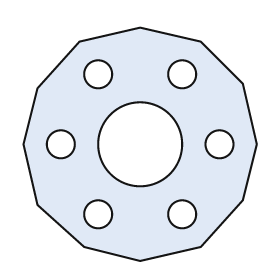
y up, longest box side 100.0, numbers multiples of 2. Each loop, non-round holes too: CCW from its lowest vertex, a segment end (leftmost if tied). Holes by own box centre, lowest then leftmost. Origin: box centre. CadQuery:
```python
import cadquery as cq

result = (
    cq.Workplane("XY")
    .moveTo(0.0, -50.0)
    .lineTo(26.0, -44.0)
    .lineTo(44.0, -24.0)
    .lineTo(50.0, 0.0)
    .lineTo(44.0, 26.0)
    .lineTo(26.0, 44.0)
    .lineTo(0.0, 50.0)
    .lineTo(-26.0, 44.0)
    .lineTo(-44.0, 24.0)
    .lineTo(-50.0, 0.0)
    .lineTo(-44.0, -26.0)
    .lineTo(-24.0, -44.0)
    .close()
    .moveTo(-18.0, -30.0)
    .circle(6.0)
    .moveTo(18.0, -30.0)
    .circle(6.0)
    .moveTo(-34.0, 0.0)
    .circle(6.0)
    .moveTo(0.0, 0.0)
    .circle(18.0)
    .moveTo(34.0, 0.0)
    .circle(6.0)
    .moveTo(-18.0, 30.0)
    .circle(6.0)
    .moveTo(18.0, 30.0)
    .circle(6.0)
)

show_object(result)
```